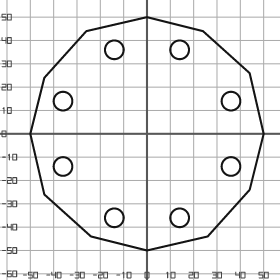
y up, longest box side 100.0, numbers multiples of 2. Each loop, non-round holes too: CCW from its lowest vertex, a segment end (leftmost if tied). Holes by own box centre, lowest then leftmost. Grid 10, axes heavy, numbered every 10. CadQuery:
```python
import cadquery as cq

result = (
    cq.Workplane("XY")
    .moveTo(0.0, -50.0)
    .lineTo(26.0, -44.0)
    .lineTo(44.0, -24.0)
    .lineTo(50.0, 0.0)
    .lineTo(44.0, 26.0)
    .lineTo(24.0, 44.0)
    .lineTo(0.0, 50.0)
    .lineTo(-26.0, 44.0)
    .lineTo(-44.0, 24.0)
    .lineTo(-50.0, 0.0)
    .lineTo(-44.0, -26.0)
    .lineTo(-24.0, -44.0)
    .close()
    .moveTo(-14.0, -36.0)
    .circle(4.0)
    .moveTo(14.0, -36.0)
    .circle(4.0)
    .moveTo(-36.0, -14.0)
    .circle(4.0)
    .moveTo(36.0, -14.0)
    .circle(4.0)
    .moveTo(-36.0, 14.0)
    .circle(4.0)
    .moveTo(36.0, 14.0)
    .circle(4.0)
    .moveTo(-14.0, 36.0)
    .circle(4.0)
    .moveTo(14.0, 36.0)
    .circle(4.0)
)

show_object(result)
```